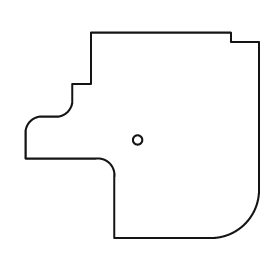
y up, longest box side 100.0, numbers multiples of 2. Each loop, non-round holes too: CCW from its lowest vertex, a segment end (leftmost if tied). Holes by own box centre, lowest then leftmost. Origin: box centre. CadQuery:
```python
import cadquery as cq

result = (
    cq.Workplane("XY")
    .moveTo(-12.0, -44.0)
    .lineTo(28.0, -44.0)
    .threePointArc((44.0, -38.0), (50.0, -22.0))
    .lineTo(50.0, 40.0)
    .lineTo(38.0, 40.0)
    .lineTo(38.0, 44.0)
    .lineTo(-22.0, 44.0)
    .lineTo(-22.0, 22.0)
    .lineTo(-30.0, 22.0)
    .lineTo(-30.0, 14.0)
    .threePointArc((-32.0, 10.0), (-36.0, 8.0))
    .lineTo(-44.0, 8.0)
    .threePointArc((-48.0, 6.0), (-50.0, 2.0))
    .lineTo(-50.0, -10.0)
    .lineTo(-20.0, -10.0)
    .threePointArc((-14.0, -12.0), (-12.0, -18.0))
    .close()
    .moveTo(-2.0, -2.0)
    .circle(2.0)
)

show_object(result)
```